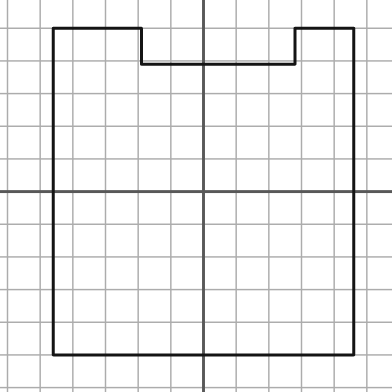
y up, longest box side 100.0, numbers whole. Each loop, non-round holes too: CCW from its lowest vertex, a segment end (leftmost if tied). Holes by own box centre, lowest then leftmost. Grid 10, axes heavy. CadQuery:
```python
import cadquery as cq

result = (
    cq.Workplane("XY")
    .moveTo(-46.0, -50.0)
    .lineTo(46.0, -50.0)
    .lineTo(46.0, 50.0)
    .lineTo(28.0, 50.0)
    .lineTo(28.0, 39.0)
    .lineTo(-19.0, 39.0)
    .lineTo(-19.0, 50.0)
    .lineTo(-46.0, 50.0)
    .close()
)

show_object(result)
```